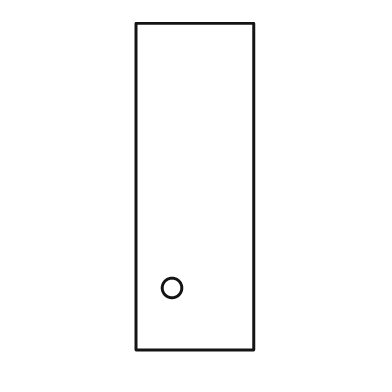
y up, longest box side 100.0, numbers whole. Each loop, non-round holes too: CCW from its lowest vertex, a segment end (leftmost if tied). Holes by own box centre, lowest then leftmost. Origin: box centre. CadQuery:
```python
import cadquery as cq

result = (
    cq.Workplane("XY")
    .moveTo(-18.0, -50.0)
    .lineTo(18.0, -50.0)
    .lineTo(18.0, 50.0)
    .lineTo(-18.0, 50.0)
    .close()
    .moveTo(-7.0, -31.0)
    .circle(3.0)
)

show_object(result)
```